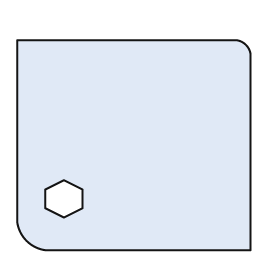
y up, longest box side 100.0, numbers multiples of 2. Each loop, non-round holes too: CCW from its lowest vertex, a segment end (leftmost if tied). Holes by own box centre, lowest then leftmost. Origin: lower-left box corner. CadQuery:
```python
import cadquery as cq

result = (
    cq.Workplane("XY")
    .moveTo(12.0, 0.0)
    .lineTo(100.0, 0.0)
    .lineTo(100.0, 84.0)
    .threePointArc((98.0, 88.0), (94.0, 90.0))
    .lineTo(0.0, 90.0)
    .lineTo(0.0, 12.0)
    .threePointArc((4.0, 4.0), (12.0, 0.0))
    .close()
    .moveTo(20.0, 14.0)
    .lineTo(28.0, 18.0)
    .lineTo(28.0, 26.0)
    .lineTo(20.0, 30.0)
    .lineTo(12.0, 26.0)
    .lineTo(12.0, 18.0)
    .close()
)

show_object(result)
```